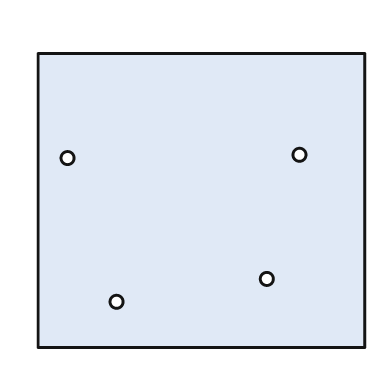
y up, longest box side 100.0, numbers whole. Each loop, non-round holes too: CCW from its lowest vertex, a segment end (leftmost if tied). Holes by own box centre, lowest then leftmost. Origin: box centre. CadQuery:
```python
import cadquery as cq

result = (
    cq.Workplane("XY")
    .moveTo(-50.0, -45.0)
    .lineTo(50.0, -45.0)
    .lineTo(50.0, 45.0)
    .lineTo(-50.0, 45.0)
    .close()
    .moveTo(-26.0, -31.0)
    .circle(2.0)
    .moveTo(20.0, -24.0)
    .circle(2.0)
    .moveTo(-41.0, 13.0)
    .circle(2.0)
    .moveTo(30.0, 14.0)
    .circle(2.0)
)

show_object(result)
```